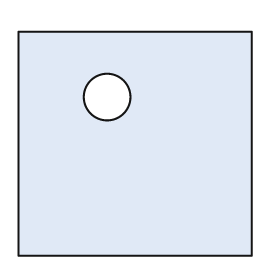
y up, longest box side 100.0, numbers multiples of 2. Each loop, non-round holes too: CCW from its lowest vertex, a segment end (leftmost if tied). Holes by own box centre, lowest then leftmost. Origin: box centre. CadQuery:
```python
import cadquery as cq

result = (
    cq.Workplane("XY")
    .moveTo(-50.0, -48.0)
    .lineTo(50.0, -48.0)
    .lineTo(50.0, 48.0)
    .lineTo(-50.0, 48.0)
    .close()
    .moveTo(-12.0, 20.0)
    .circle(10.0)
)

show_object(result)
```